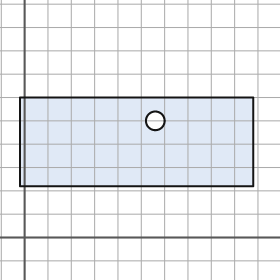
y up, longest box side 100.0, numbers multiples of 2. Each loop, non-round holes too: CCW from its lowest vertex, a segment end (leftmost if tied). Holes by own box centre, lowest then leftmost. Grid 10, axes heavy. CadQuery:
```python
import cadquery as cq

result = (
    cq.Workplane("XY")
    .moveTo(-2.0, 22.0)
    .lineTo(98.0, 22.0)
    .lineTo(98.0, 60.0)
    .lineTo(-2.0, 60.0)
    .close()
    .moveTo(56.0, 50.0)
    .circle(4.0)
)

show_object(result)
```